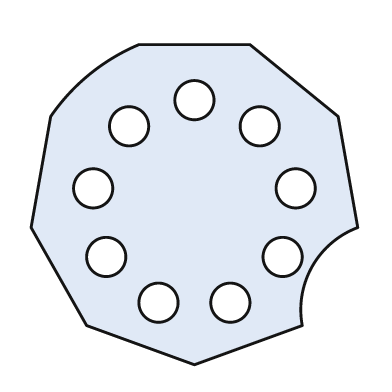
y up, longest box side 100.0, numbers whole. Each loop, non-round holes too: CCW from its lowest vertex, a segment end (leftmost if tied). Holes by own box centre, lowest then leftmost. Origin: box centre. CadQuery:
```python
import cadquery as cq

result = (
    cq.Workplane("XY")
    .moveTo(0.0, -49.0)
    .lineTo(33.0, -37.0)
    .threePointArc((36.0, -19.0), (50.0, -7.0))
    .lineTo(44.0, 27.0)
    .lineTo(17.0, 49.0)
    .lineTo(-17.0, 49.0)
    .threePointArc((-32.0, 40.0), (-44.0, 27.0))
    .lineTo(-50.0, -7.0)
    .lineTo(-33.0, -37.0)
    .close()
    .moveTo(-11.0, -30.0)
    .circle(6.0)
    .moveTo(11.0, -30.0)
    .circle(6.0)
    .moveTo(-27.0, -16.0)
    .circle(6.0)
    .moveTo(27.0, -16.0)
    .circle(6.0)
    .moveTo(-31.0, 5.0)
    .circle(6.0)
    .moveTo(31.0, 5.0)
    .circle(6.0)
    .moveTo(-20.0, 24.0)
    .circle(6.0)
    .moveTo(20.0, 24.0)
    .circle(6.0)
    .moveTo(0.0, 32.0)
    .circle(6.0)
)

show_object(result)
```